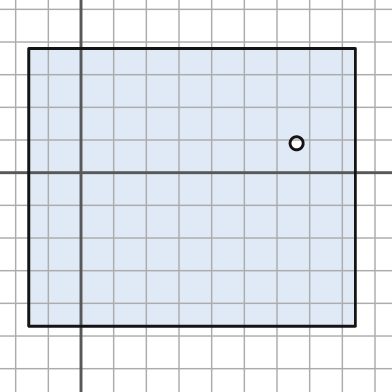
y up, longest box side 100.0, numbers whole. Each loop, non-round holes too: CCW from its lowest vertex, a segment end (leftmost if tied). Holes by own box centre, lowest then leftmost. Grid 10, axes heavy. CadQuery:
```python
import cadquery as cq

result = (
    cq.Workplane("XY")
    .moveTo(-16.0, -47.0)
    .lineTo(84.0, -47.0)
    .lineTo(84.0, 38.0)
    .lineTo(-16.0, 38.0)
    .close()
    .moveTo(66.0, 9.0)
    .circle(2.0)
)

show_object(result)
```